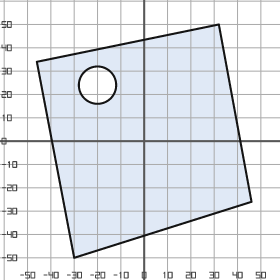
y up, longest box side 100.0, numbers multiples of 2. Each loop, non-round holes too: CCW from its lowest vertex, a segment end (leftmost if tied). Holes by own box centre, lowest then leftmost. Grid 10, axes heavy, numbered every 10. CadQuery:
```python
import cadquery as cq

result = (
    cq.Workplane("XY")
    .moveTo(-30.0, -50.0)
    .lineTo(46.0, -26.0)
    .lineTo(32.0, 50.0)
    .lineTo(-46.0, 34.0)
    .close()
    .moveTo(-20.0, 24.0)
    .circle(8.0)
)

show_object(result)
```